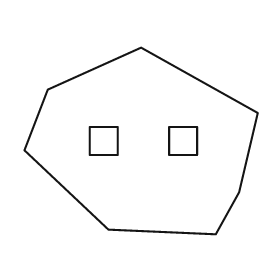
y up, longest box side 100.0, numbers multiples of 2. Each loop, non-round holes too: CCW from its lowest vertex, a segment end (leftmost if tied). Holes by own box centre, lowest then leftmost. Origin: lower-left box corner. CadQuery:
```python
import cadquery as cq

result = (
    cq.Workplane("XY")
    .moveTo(82.0, 0.0)
    .lineTo(92.0, 18.0)
    .lineTo(100.0, 52.0)
    .lineTo(50.0, 80.0)
    .lineTo(10.0, 62.0)
    .lineTo(0.0, 36.0)
    .lineTo(36.0, 2.0)
    .close()
    .moveTo(28.0, 34.0)
    .lineTo(40.0, 34.0)
    .lineTo(40.0, 46.0)
    .lineTo(28.0, 46.0)
    .close()
    .moveTo(62.0, 34.0)
    .lineTo(74.0, 34.0)
    .lineTo(74.0, 46.0)
    .lineTo(62.0, 46.0)
    .close()
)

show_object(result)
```